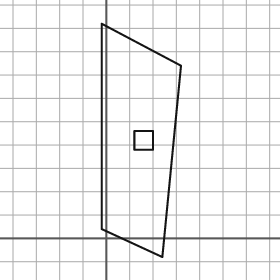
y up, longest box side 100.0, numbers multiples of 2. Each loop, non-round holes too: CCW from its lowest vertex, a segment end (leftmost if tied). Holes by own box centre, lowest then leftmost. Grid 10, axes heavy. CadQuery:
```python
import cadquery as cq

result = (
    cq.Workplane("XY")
    .moveTo(24.0, -8.0)
    .lineTo(32.0, 74.0)
    .lineTo(-2.0, 92.0)
    .lineTo(-2.0, 4.0)
    .close()
    .moveTo(12.0, 38.0)
    .lineTo(20.0, 38.0)
    .lineTo(20.0, 46.0)
    .lineTo(12.0, 46.0)
    .close()
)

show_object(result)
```